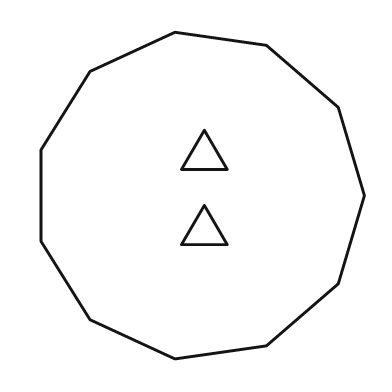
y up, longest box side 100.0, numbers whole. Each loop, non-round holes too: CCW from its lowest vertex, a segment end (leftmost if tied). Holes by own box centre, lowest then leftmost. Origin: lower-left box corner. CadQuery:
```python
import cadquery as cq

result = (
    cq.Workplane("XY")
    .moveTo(41.0, 0.0)
    .lineTo(69.0, 4.0)
    .lineTo(91.0, 23.0)
    .lineTo(99.0, 50.0)
    .lineTo(91.0, 77.0)
    .lineTo(69.0, 96.0)
    .lineTo(41.0, 100.0)
    .lineTo(15.0, 88.0)
    .lineTo(0.0, 64.0)
    .lineTo(0.0, 36.0)
    .lineTo(15.0, 12.0)
    .close()
    .moveTo(43.0, 35.0)
    .lineTo(57.0, 35.0)
    .lineTo(50.0, 47.0)
    .close()
    .moveTo(43.0, 58.0)
    .lineTo(57.0, 58.0)
    .lineTo(50.0, 70.0)
    .close()
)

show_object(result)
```